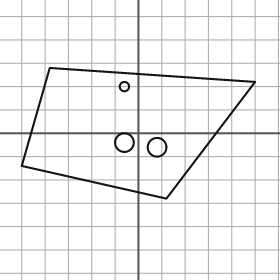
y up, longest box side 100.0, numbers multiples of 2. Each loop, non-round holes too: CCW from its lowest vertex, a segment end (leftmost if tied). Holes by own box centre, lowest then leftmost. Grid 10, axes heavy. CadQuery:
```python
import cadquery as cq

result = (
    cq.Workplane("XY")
    .moveTo(12.0, -28.0)
    .lineTo(50.0, 22.0)
    .lineTo(-38.0, 28.0)
    .lineTo(-50.0, -14.0)
    .close()
    .moveTo(8.0, -6.0)
    .circle(4.0)
    .moveTo(-6.0, -4.0)
    .circle(4.0)
    .moveTo(-6.0, 20.0)
    .circle(2.0)
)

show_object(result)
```